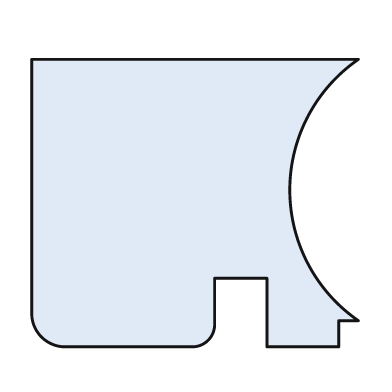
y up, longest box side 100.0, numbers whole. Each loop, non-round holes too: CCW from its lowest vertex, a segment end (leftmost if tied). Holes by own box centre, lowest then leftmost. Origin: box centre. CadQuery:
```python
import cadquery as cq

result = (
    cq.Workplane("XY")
    .moveTo(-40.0, -44.0)
    .lineTo(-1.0, -44.0)
    .threePointArc((4.0, -42.0), (6.0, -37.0))
    .lineTo(6.0, -23.0)
    .lineTo(22.0, -23.0)
    .lineTo(22.0, -44.0)
    .lineTo(44.0, -44.0)
    .lineTo(44.0, -36.0)
    .lineTo(50.0, -36.0)
    .threePointArc((29.0, 4.0), (50.0, 44.0))
    .lineTo(-50.0, 44.0)
    .lineTo(-50.0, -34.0)
    .threePointArc((-47.0, -41.0), (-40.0, -44.0))
    .close()
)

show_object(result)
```